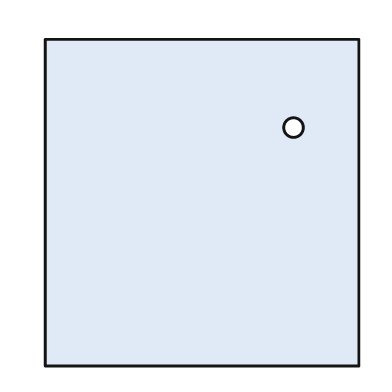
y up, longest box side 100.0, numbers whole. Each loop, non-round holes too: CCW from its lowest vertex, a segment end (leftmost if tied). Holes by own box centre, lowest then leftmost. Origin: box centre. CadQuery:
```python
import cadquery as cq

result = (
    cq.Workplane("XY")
    .moveTo(-48.0, -50.0)
    .lineTo(48.0, -50.0)
    .lineTo(48.0, 50.0)
    .lineTo(-48.0, 50.0)
    .close()
    .moveTo(28.0, 23.0)
    .circle(3.0)
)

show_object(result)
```